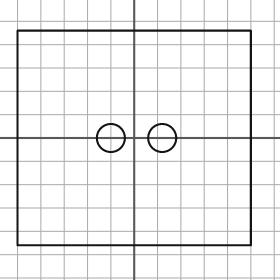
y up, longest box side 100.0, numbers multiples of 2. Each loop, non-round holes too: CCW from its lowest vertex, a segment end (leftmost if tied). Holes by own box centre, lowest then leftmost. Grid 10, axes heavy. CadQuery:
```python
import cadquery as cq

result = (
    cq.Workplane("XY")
    .moveTo(-50.0, -46.0)
    .lineTo(50.0, -46.0)
    .lineTo(50.0, 46.0)
    .lineTo(-50.0, 46.0)
    .close()
    .moveTo(-10.0, 0.0)
    .circle(6.0)
    .moveTo(12.0, 0.0)
    .circle(6.0)
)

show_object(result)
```